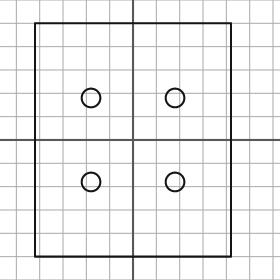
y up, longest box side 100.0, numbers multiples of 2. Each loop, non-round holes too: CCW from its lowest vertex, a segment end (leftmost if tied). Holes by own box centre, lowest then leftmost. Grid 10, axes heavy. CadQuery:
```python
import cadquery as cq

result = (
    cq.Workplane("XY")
    .moveTo(-42.0, -50.0)
    .lineTo(42.0, -50.0)
    .lineTo(42.0, 50.0)
    .lineTo(-42.0, 50.0)
    .close()
    .moveTo(-18.0, -18.0)
    .circle(4.0)
    .moveTo(18.0, -18.0)
    .circle(4.0)
    .moveTo(-18.0, 18.0)
    .circle(4.0)
    .moveTo(18.0, 18.0)
    .circle(4.0)
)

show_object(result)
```